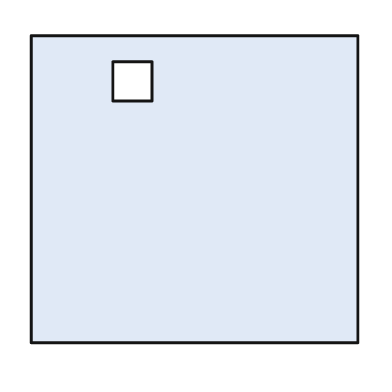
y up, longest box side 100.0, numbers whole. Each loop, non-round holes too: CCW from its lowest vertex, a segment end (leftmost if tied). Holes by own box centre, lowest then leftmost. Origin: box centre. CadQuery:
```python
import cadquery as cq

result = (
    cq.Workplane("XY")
    .moveTo(-50.0, -47.0)
    .lineTo(50.0, -47.0)
    .lineTo(50.0, 47.0)
    .lineTo(-50.0, 47.0)
    .close()
    .moveTo(-25.0, 27.0)
    .lineTo(-13.0, 27.0)
    .lineTo(-13.0, 39.0)
    .lineTo(-25.0, 39.0)
    .close()
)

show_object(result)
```